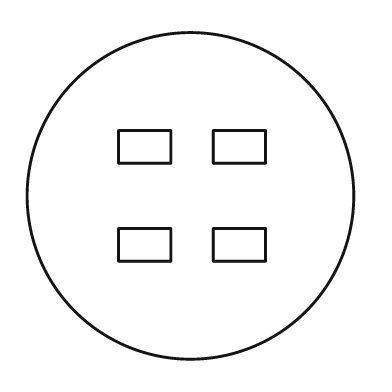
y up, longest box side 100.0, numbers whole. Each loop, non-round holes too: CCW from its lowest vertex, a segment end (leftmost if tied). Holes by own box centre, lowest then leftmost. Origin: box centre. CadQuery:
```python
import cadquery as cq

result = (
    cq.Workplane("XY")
    .moveTo(0.0, 0.0)
    .circle(50.0)
    .moveTo(-22.0, -20.0)
    .lineTo(-6.0, -20.0)
    .lineTo(-6.0, -10.0)
    .lineTo(-22.0, -10.0)
    .close()
    .moveTo(7.0, -20.0)
    .lineTo(23.0, -20.0)
    .lineTo(23.0, -10.0)
    .lineTo(7.0, -10.0)
    .close()
    .moveTo(-22.0, 10.0)
    .lineTo(-6.0, 10.0)
    .lineTo(-6.0, 20.0)
    .lineTo(-22.0, 20.0)
    .close()
    .moveTo(7.0, 10.0)
    .lineTo(23.0, 10.0)
    .lineTo(23.0, 20.0)
    .lineTo(7.0, 20.0)
    .close()
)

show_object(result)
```